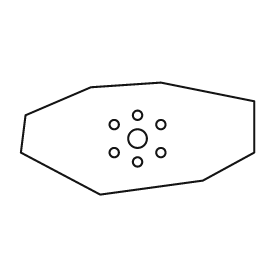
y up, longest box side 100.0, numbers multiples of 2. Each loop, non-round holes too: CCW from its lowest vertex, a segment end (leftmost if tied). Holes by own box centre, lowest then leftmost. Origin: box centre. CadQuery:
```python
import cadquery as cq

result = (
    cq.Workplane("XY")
    .moveTo(-16.0, -24.0)
    .lineTo(28.0, -18.0)
    .lineTo(50.0, -6.0)
    .lineTo(50.0, 16.0)
    .lineTo(10.0, 24.0)
    .lineTo(-20.0, 22.0)
    .lineTo(-48.0, 10.0)
    .lineTo(-50.0, -6.0)
    .close()
    .moveTo(0.0, -10.0)
    .circle(2.0)
    .moveTo(-10.0, -6.0)
    .circle(2.0)
    .moveTo(10.0, -6.0)
    .circle(2.0)
    .moveTo(0.0, 0.0)
    .circle(4.0)
    .moveTo(-10.0, 6.0)
    .circle(2.0)
    .moveTo(10.0, 6.0)
    .circle(2.0)
    .moveTo(0.0, 10.0)
    .circle(2.0)
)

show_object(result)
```